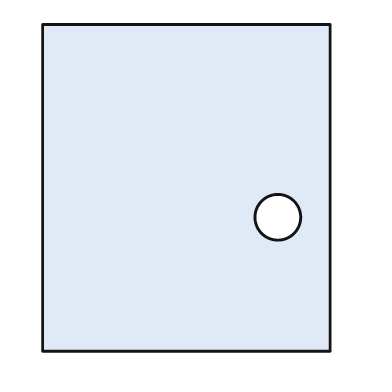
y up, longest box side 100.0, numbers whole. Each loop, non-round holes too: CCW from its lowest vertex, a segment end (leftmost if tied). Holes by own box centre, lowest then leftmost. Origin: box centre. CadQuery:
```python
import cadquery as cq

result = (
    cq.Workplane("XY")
    .moveTo(-44.0, -50.0)
    .lineTo(44.0, -50.0)
    .lineTo(44.0, 50.0)
    .lineTo(-44.0, 50.0)
    .close()
    .moveTo(28.0, -9.0)
    .circle(7.0)
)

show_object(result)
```